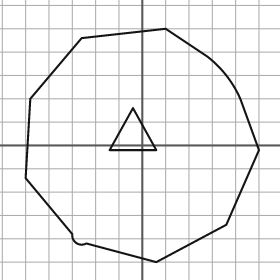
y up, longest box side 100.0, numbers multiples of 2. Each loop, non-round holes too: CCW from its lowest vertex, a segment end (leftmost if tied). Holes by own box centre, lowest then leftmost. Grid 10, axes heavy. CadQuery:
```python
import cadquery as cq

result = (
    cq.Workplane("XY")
    .moveTo(6.0, -50.0)
    .lineTo(36.0, -34.0)
    .lineTo(50.0, -2.0)
    .lineTo(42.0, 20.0)
    .threePointArc((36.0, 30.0), (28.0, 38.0))
    .lineTo(10.0, 50.0)
    .lineTo(-26.0, 46.0)
    .lineTo(-48.0, 20.0)
    .lineTo(-50.0, -14.0)
    .lineTo(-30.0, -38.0)
    .threePointArc((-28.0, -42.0), (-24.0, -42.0))
    .close()
    .moveTo(-14.0, -2.0)
    .lineTo(6.0, -2.0)
    .lineTo(-4.0, 16.0)
    .close()
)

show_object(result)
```